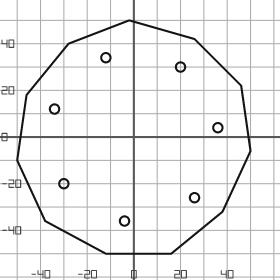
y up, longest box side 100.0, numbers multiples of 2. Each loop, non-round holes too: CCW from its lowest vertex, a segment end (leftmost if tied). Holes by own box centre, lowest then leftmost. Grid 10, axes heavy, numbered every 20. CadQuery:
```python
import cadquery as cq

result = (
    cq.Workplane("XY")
    .moveTo(-12.0, -50.0)
    .lineTo(16.0, -50.0)
    .lineTo(38.0, -32.0)
    .lineTo(50.0, -6.0)
    .lineTo(46.0, 22.0)
    .lineTo(26.0, 42.0)
    .lineTo(-2.0, 50.0)
    .lineTo(-28.0, 40.0)
    .lineTo(-46.0, 18.0)
    .lineTo(-50.0, -10.0)
    .lineTo(-38.0, -36.0)
    .close()
    .moveTo(-4.0, -36.0)
    .circle(2.0)
    .moveTo(26.0, -26.0)
    .circle(2.0)
    .moveTo(-30.0, -20.0)
    .circle(2.0)
    .moveTo(36.0, 4.0)
    .circle(2.0)
    .moveTo(-34.0, 12.0)
    .circle(2.0)
    .moveTo(20.0, 30.0)
    .circle(2.0)
    .moveTo(-12.0, 34.0)
    .circle(2.0)
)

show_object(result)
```